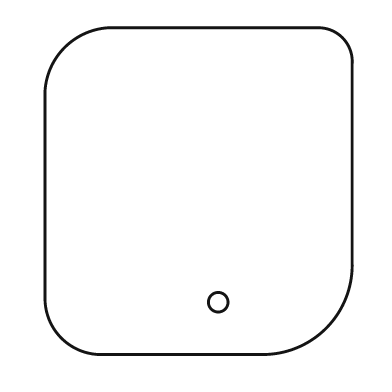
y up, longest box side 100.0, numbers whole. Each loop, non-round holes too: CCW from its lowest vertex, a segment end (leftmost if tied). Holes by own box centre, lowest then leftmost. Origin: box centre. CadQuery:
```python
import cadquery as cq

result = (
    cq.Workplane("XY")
    .moveTo(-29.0, -50.0)
    .lineTo(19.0, -50.0)
    .threePointArc((39.0, -42.0), (47.0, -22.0))
    .lineTo(47.0, 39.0)
    .threePointArc((44.0, 47.0), (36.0, 50.0))
    .lineTo(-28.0, 50.0)
    .threePointArc((-41.0, 44.0), (-47.0, 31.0))
    .lineTo(-47.0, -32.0)
    .threePointArc((-42.0, -45.0), (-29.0, -50.0))
    .close()
    .moveTo(6.0, -34.0)
    .circle(3.0)
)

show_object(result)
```